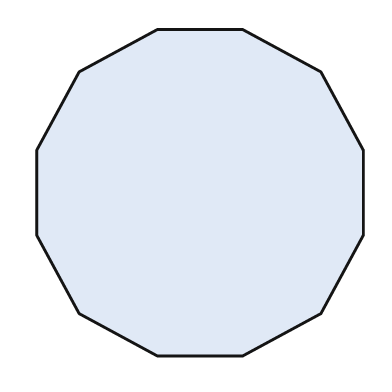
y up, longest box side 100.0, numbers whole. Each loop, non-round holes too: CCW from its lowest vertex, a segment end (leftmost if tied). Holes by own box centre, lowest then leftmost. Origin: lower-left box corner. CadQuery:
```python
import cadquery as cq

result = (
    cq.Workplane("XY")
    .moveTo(37.0, 0.0)
    .lineTo(63.0, 0.0)
    .lineTo(87.0, 13.0)
    .lineTo(100.0, 37.0)
    .lineTo(100.0, 63.0)
    .lineTo(87.0, 87.0)
    .lineTo(63.0, 100.0)
    .lineTo(37.0, 100.0)
    .lineTo(13.0, 87.0)
    .lineTo(0.0, 63.0)
    .lineTo(0.0, 37.0)
    .lineTo(13.0, 13.0)
    .close()
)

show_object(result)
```